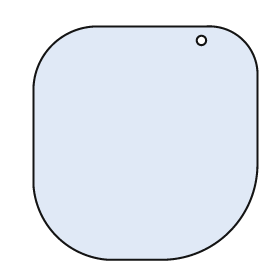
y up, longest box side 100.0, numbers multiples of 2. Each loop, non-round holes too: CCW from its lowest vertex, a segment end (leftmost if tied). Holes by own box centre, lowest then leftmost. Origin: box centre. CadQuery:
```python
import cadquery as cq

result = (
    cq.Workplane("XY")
    .moveTo(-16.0, -50.0)
    .lineTo(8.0, -50.0)
    .threePointArc((36.0, -38.0), (48.0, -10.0))
    .lineTo(48.0, 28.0)
    .threePointArc((42.0, 44.0), (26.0, 50.0))
    .lineTo(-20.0, 50.0)
    .threePointArc((-40.0, 42.0), (-48.0, 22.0))
    .lineTo(-48.0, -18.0)
    .threePointArc((-38.0, -40.0), (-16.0, -50.0))
    .close()
    .moveTo(24.0, 44.0)
    .circle(2.0)
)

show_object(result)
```